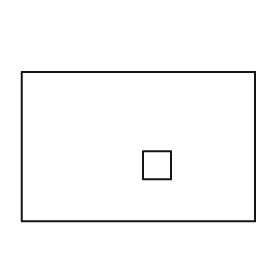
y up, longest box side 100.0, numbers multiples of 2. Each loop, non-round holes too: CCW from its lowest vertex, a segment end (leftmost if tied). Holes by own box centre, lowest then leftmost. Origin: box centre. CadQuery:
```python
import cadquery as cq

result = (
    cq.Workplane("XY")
    .moveTo(-50.0, -32.0)
    .lineTo(50.0, -32.0)
    .lineTo(50.0, 32.0)
    .lineTo(-50.0, 32.0)
    .close()
    .moveTo(2.0, -14.0)
    .lineTo(14.0, -14.0)
    .lineTo(14.0, -2.0)
    .lineTo(2.0, -2.0)
    .close()
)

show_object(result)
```